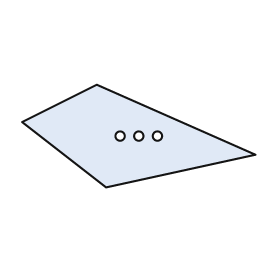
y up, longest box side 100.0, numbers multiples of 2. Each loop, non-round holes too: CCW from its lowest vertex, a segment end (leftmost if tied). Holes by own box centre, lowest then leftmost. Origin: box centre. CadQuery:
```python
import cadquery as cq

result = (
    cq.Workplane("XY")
    .moveTo(-14.0, -22.0)
    .lineTo(50.0, -8.0)
    .lineTo(-18.0, 22.0)
    .lineTo(-50.0, 6.0)
    .close()
    .moveTo(-8.0, 0.0)
    .circle(2.0)
    .moveTo(0.0, 0.0)
    .circle(2.0)
    .moveTo(8.0, 0.0)
    .circle(2.0)
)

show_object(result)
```